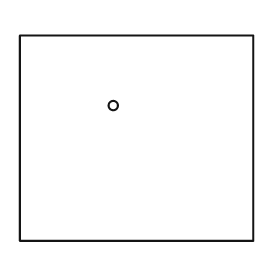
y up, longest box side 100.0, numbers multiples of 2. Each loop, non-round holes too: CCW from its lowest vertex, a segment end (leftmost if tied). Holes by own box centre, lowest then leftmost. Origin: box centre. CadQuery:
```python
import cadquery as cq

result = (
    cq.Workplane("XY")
    .moveTo(-50.0, -44.0)
    .lineTo(50.0, -44.0)
    .lineTo(50.0, 44.0)
    .lineTo(-50.0, 44.0)
    .close()
    .moveTo(-10.0, 14.0)
    .circle(2.0)
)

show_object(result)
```